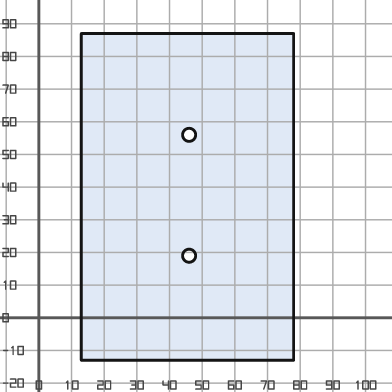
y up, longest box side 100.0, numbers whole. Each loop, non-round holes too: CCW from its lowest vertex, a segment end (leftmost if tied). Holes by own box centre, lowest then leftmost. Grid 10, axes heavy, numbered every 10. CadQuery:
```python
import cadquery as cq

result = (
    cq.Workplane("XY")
    .moveTo(13.0, -13.0)
    .lineTo(78.0, -13.0)
    .lineTo(78.0, 87.0)
    .lineTo(13.0, 87.0)
    .close()
    .moveTo(46.0, 19.0)
    .circle(2.0)
    .moveTo(46.0, 56.0)
    .circle(2.0)
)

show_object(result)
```